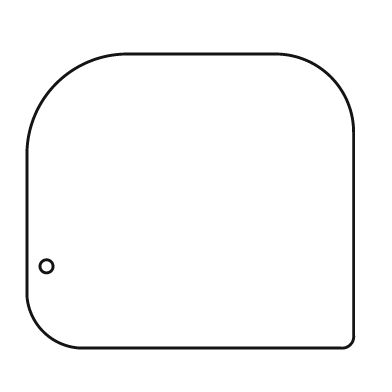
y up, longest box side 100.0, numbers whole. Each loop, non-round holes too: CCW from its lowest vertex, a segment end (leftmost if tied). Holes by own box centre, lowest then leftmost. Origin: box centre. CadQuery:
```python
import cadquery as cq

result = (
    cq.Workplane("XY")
    .moveTo(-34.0, -45.0)
    .lineTo(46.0, -45.0)
    .threePointArc((49.0, -44.0), (50.0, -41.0))
    .lineTo(50.0, 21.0)
    .threePointArc((43.0, 38.0), (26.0, 45.0))
    .lineTo(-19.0, 45.0)
    .threePointArc((-41.0, 36.0), (-50.0, 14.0))
    .lineTo(-50.0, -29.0)
    .threePointArc((-45.0, -40.0), (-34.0, -45.0))
    .close()
    .moveTo(-44.0, -20.0)
    .circle(2.0)
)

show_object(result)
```